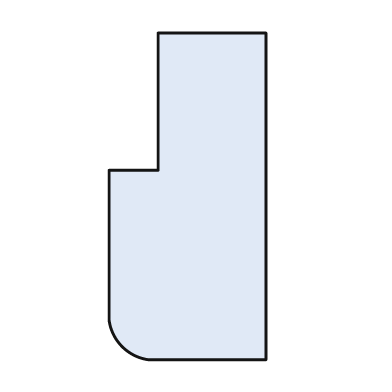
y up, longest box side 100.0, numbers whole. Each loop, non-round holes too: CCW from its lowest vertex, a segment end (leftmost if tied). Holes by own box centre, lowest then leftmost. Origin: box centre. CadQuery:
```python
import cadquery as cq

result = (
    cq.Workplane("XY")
    .moveTo(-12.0, -50.0)
    .lineTo(24.0, -50.0)
    .lineTo(24.0, 50.0)
    .lineTo(-9.0, 50.0)
    .lineTo(-9.0, 8.0)
    .lineTo(-24.0, 8.0)
    .lineTo(-24.0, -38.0)
    .threePointArc((-20.0, -46.0), (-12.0, -50.0))
    .close()
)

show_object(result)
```